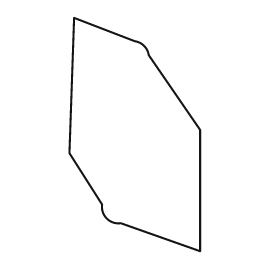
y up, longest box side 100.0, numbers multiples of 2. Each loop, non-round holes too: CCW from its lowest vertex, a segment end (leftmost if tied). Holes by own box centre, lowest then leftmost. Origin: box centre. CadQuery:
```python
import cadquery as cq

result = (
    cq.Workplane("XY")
    .moveTo(28.0, -50.0)
    .lineTo(28.0, 2.0)
    .lineTo(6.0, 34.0)
    .threePointArc((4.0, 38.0), (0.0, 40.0))
    .lineTo(-26.0, 50.0)
    .lineTo(-28.0, -8.0)
    .lineTo(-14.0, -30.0)
    .threePointArc((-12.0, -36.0), (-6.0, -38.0))
    .close()
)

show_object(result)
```